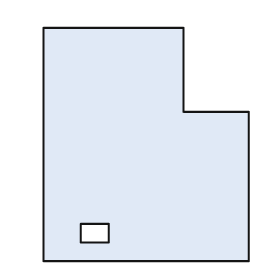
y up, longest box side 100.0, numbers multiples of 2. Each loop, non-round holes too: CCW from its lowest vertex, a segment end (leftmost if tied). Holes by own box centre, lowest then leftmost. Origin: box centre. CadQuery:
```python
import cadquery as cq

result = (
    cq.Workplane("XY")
    .moveTo(-44.0, -50.0)
    .lineTo(44.0, -50.0)
    .lineTo(44.0, 14.0)
    .lineTo(16.0, 14.0)
    .lineTo(16.0, 50.0)
    .lineTo(-44.0, 50.0)
    .close()
    .moveTo(-28.0, -42.0)
    .lineTo(-16.0, -42.0)
    .lineTo(-16.0, -34.0)
    .lineTo(-28.0, -34.0)
    .close()
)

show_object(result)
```